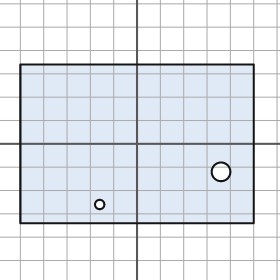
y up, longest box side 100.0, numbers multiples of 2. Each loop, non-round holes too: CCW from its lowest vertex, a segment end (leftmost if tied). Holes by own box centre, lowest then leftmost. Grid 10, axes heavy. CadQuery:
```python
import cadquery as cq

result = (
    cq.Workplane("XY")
    .moveTo(-50.0, -34.0)
    .lineTo(50.0, -34.0)
    .lineTo(50.0, 34.0)
    .lineTo(-50.0, 34.0)
    .close()
    .moveTo(-16.0, -26.0)
    .circle(2.0)
    .moveTo(36.0, -12.0)
    .circle(4.0)
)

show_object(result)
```